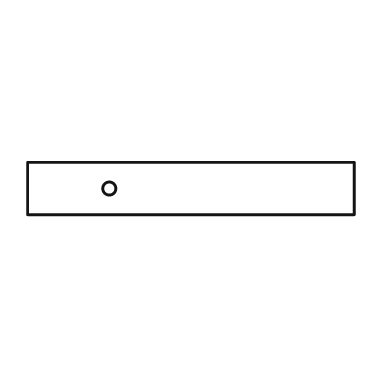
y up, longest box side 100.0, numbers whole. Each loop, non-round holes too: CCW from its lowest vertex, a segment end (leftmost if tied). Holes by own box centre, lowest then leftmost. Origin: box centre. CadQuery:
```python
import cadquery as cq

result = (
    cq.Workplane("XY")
    .moveTo(-50.0, -8.0)
    .lineTo(50.0, -8.0)
    .lineTo(50.0, 8.0)
    .lineTo(-50.0, 8.0)
    .close()
    .moveTo(-25.0, 0.0)
    .circle(2.0)
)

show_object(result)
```